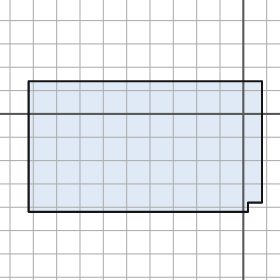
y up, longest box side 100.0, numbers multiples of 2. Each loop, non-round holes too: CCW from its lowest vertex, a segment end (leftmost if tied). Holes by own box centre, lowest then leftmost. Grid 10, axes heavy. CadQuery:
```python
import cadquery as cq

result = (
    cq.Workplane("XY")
    .moveTo(-92.0, -42.0)
    .lineTo(2.0, -42.0)
    .lineTo(2.0, -38.0)
    .lineTo(8.0, -38.0)
    .lineTo(8.0, 14.0)
    .lineTo(-92.0, 14.0)
    .close()
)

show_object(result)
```